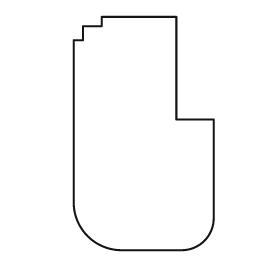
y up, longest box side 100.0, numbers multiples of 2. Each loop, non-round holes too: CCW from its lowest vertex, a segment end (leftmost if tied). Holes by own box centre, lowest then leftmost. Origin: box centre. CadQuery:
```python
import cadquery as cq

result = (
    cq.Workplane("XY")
    .moveTo(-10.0, -50.0)
    .lineTo(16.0, -50.0)
    .threePointArc((26.0, -46.0), (30.0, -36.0))
    .lineTo(30.0, 6.0)
    .lineTo(14.0, 6.0)
    .lineTo(14.0, 50.0)
    .lineTo(-18.0, 50.0)
    .lineTo(-18.0, 46.0)
    .lineTo(-26.0, 46.0)
    .lineTo(-26.0, 40.0)
    .lineTo(-30.0, 40.0)
    .lineTo(-30.0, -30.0)
    .threePointArc((-24.0, -44.0), (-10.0, -50.0))
    .close()
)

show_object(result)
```